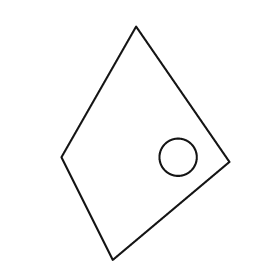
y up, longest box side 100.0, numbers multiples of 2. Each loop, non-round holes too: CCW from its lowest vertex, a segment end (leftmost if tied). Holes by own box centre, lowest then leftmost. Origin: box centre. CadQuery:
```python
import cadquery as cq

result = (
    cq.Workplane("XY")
    .moveTo(-14.0, -50.0)
    .lineTo(36.0, -8.0)
    .lineTo(-4.0, 50.0)
    .lineTo(-36.0, -6.0)
    .close()
    .moveTo(14.0, -6.0)
    .circle(8.0)
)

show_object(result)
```